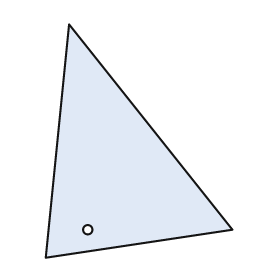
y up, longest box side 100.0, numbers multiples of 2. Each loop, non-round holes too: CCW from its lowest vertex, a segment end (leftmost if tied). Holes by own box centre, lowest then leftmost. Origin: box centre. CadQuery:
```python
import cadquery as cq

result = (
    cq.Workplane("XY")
    .moveTo(-40.0, -50.0)
    .lineTo(40.0, -38.0)
    .lineTo(-30.0, 50.0)
    .close()
    .moveTo(-22.0, -38.0)
    .circle(2.0)
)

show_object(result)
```